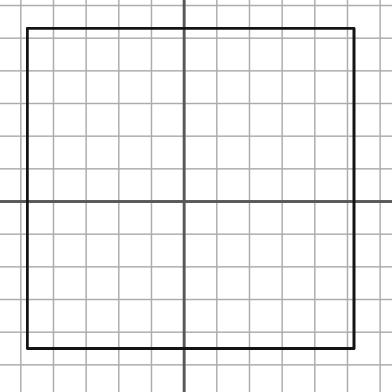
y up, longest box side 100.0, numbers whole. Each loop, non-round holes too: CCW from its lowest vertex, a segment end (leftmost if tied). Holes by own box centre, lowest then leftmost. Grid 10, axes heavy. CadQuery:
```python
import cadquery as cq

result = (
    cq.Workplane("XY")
    .moveTo(-48.0, -45.0)
    .lineTo(52.0, -45.0)
    .lineTo(52.0, 53.0)
    .lineTo(-48.0, 53.0)
    .close()
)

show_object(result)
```